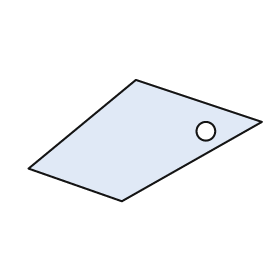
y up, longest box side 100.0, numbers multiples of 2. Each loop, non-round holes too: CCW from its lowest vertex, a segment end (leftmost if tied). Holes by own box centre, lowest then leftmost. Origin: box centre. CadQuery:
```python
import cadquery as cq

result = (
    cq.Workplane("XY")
    .moveTo(-10.0, -26.0)
    .lineTo(50.0, 8.0)
    .lineTo(-4.0, 26.0)
    .lineTo(-50.0, -12.0)
    .close()
    .moveTo(26.0, 4.0)
    .circle(4.0)
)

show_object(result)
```